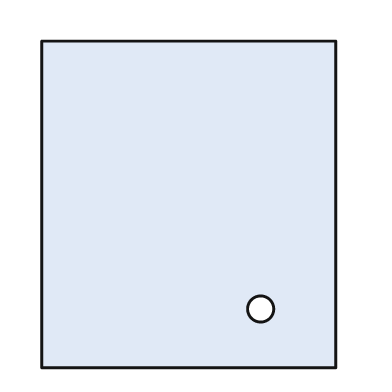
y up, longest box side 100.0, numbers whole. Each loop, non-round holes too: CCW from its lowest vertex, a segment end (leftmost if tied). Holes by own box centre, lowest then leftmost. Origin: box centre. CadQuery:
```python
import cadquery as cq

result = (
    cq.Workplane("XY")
    .moveTo(-45.0, -50.0)
    .lineTo(45.0, -50.0)
    .lineTo(45.0, 50.0)
    .lineTo(-45.0, 50.0)
    .close()
    .moveTo(22.0, -32.0)
    .circle(4.0)
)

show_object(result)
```